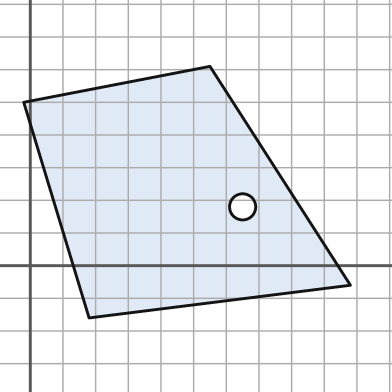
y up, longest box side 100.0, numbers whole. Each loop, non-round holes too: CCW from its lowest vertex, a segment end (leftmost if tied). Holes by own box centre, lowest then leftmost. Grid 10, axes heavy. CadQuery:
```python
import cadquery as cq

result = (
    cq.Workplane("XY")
    .moveTo(18.0, -16.0)
    .lineTo(98.0, -6.0)
    .lineTo(55.0, 61.0)
    .lineTo(-2.0, 50.0)
    .close()
    .moveTo(65.0, 18.0)
    .circle(4.0)
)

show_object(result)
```